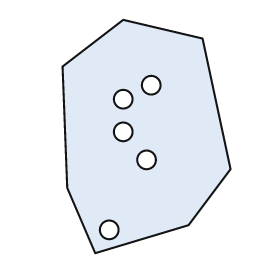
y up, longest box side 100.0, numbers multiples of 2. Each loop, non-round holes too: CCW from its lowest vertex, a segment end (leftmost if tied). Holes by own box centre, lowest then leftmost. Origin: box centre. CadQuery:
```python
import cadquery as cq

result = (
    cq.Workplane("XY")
    .moveTo(-22.0, -50.0)
    .lineTo(18.0, -38.0)
    .lineTo(36.0, -14.0)
    .lineTo(24.0, 42.0)
    .lineTo(-10.0, 50.0)
    .lineTo(-36.0, 30.0)
    .lineTo(-34.0, -22.0)
    .close()
    .moveTo(-16.0, -40.0)
    .circle(4.0)
    .moveTo(0.0, -10.0)
    .circle(4.0)
    .moveTo(-10.0, 2.0)
    .circle(4.0)
    .moveTo(-10.0, 16.0)
    .circle(4.0)
    .moveTo(2.0, 22.0)
    .circle(4.0)
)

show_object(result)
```